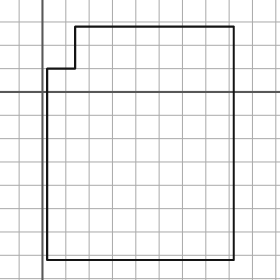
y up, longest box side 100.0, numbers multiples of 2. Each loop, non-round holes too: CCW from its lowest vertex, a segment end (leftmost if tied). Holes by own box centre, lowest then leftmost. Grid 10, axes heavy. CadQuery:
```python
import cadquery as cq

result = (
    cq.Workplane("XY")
    .moveTo(2.0, -72.0)
    .lineTo(82.0, -72.0)
    .lineTo(82.0, 28.0)
    .lineTo(14.0, 28.0)
    .lineTo(14.0, 10.0)
    .lineTo(2.0, 10.0)
    .close()
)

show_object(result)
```